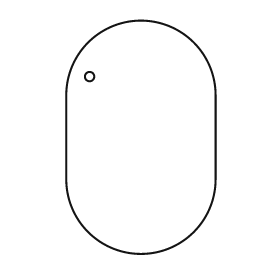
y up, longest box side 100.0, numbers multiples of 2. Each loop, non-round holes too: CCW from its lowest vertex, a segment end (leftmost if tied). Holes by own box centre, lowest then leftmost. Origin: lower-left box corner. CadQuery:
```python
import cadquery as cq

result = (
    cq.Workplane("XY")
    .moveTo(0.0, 32.0)
    .threePointArc((32.0, 0.0), (64.0, 32.0))
    .lineTo(64.0, 68.0)
    .threePointArc((32.0, 100.0), (0.0, 68.0))
    .close()
    .moveTo(10.0, 76.0)
    .circle(2.0)
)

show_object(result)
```